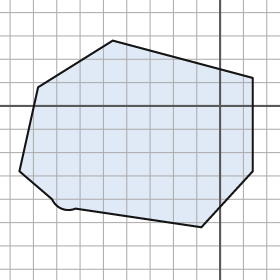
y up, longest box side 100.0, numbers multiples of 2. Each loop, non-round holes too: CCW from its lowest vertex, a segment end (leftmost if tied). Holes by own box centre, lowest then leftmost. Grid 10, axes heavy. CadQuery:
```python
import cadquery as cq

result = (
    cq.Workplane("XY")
    .moveTo(-8.0, -52.0)
    .lineTo(14.0, -28.0)
    .lineTo(14.0, 12.0)
    .lineTo(-46.0, 28.0)
    .lineTo(-78.0, 8.0)
    .lineTo(-86.0, -28.0)
    .lineTo(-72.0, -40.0)
    .threePointArc((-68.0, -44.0), (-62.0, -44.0))
    .close()
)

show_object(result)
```